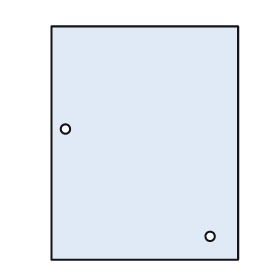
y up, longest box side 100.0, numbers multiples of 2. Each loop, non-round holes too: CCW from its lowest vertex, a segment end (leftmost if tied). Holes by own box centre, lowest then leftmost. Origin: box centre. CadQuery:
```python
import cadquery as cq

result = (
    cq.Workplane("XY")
    .moveTo(-40.0, -50.0)
    .lineTo(40.0, -50.0)
    .lineTo(40.0, 50.0)
    .lineTo(-40.0, 50.0)
    .close()
    .moveTo(28.0, -40.0)
    .circle(2.0)
    .moveTo(-34.0, 6.0)
    .circle(2.0)
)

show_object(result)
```